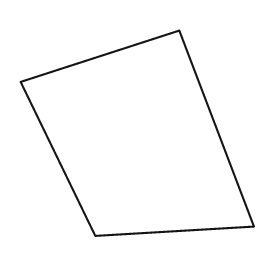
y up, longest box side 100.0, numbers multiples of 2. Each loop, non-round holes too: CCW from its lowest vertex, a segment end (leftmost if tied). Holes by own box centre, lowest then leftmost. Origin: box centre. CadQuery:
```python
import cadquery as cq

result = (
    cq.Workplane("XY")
    .moveTo(-18.0, -44.0)
    .lineTo(50.0, -40.0)
    .lineTo(18.0, 44.0)
    .lineTo(-50.0, 22.0)
    .close()
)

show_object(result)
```